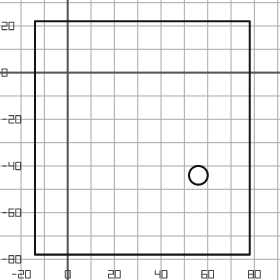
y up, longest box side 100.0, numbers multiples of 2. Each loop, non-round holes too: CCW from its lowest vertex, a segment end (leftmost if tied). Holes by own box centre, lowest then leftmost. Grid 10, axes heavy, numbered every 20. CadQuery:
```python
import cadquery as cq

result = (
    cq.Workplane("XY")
    .moveTo(-14.0, -78.0)
    .lineTo(78.0, -78.0)
    .lineTo(78.0, 22.0)
    .lineTo(-14.0, 22.0)
    .close()
    .moveTo(56.0, -44.0)
    .circle(4.0)
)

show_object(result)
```